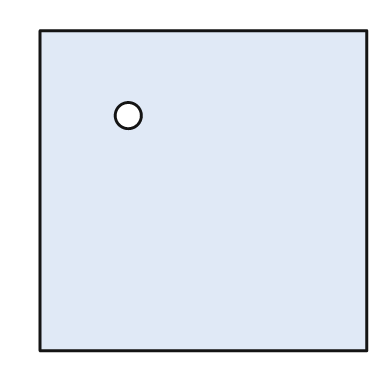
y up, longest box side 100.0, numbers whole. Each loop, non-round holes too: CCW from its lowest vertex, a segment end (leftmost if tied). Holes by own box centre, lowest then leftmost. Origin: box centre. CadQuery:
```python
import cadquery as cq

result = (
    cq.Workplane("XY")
    .moveTo(-50.0, -49.0)
    .lineTo(50.0, -49.0)
    .lineTo(50.0, 49.0)
    .lineTo(-50.0, 49.0)
    .close()
    .moveTo(-23.0, 23.0)
    .circle(4.0)
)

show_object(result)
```